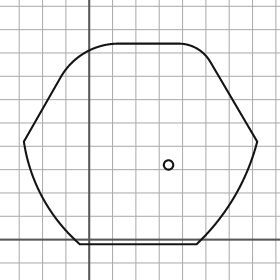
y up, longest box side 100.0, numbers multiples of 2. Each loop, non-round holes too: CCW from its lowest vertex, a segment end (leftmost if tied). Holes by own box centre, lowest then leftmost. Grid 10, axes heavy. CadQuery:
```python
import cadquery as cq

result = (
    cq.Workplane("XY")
    .moveTo(-4.0, -2.0)
    .lineTo(46.0, -2.0)
    .threePointArc((62.0, 18.0), (72.0, 42.0))
    .lineTo(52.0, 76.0)
    .threePointArc((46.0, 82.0), (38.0, 84.0))
    .lineTo(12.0, 84.0)
    .threePointArc((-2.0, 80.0), (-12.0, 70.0))
    .lineTo(-28.0, 42.0)
    .threePointArc((-20.0, 18.0), (-4.0, -2.0))
    .close()
    .moveTo(34.0, 32.0)
    .circle(2.0)
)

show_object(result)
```